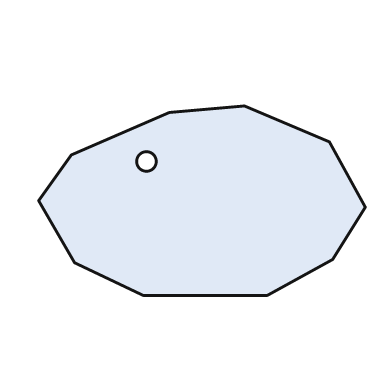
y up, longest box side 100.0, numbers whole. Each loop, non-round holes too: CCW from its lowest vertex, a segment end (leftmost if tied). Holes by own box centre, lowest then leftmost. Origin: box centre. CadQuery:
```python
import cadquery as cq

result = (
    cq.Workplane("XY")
    .moveTo(-18.0, -29.0)
    .lineTo(20.0, -29.0)
    .lineTo(40.0, -18.0)
    .lineTo(50.0, -2.0)
    .lineTo(39.0, 18.0)
    .lineTo(13.0, 29.0)
    .lineTo(-10.0, 27.0)
    .lineTo(-40.0, 14.0)
    .lineTo(-50.0, 0.0)
    .lineTo(-39.0, -19.0)
    .close()
    .moveTo(-17.0, 12.0)
    .circle(3.0)
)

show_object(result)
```